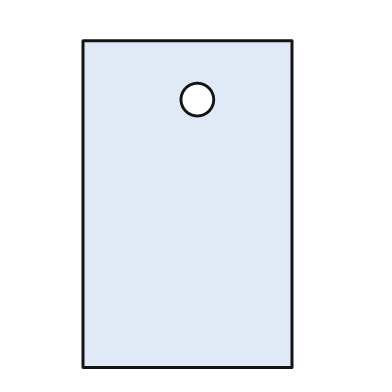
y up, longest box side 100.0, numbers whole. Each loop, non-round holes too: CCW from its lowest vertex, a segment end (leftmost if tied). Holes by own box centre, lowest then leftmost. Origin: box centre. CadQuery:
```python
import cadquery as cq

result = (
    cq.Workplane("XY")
    .moveTo(-32.0, -50.0)
    .lineTo(32.0, -50.0)
    .lineTo(32.0, 50.0)
    .lineTo(-32.0, 50.0)
    .close()
    .moveTo(3.0, 32.0)
    .circle(5.0)
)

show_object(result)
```